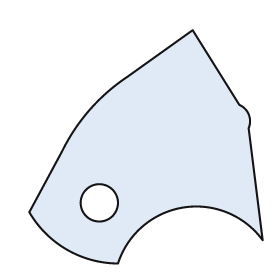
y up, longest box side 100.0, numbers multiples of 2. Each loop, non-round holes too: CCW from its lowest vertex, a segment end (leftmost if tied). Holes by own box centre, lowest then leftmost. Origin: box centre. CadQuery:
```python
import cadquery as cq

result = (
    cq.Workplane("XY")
    .moveTo(-12.0, -50.0)
    .threePointArc((16.0, -26.0), (50.0, -40.0))
    .lineTo(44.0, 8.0)
    .threePointArc((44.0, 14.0), (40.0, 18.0))
    .lineTo(20.0, 50.0)
    .lineTo(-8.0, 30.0)
    .threePointArc((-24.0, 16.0), (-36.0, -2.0))
    .lineTo(-50.0, -28.0)
    .threePointArc((-34.0, -44.0), (-12.0, -50.0))
    .close()
    .moveTo(-20.0, -24.0)
    .circle(8.0)
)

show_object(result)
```